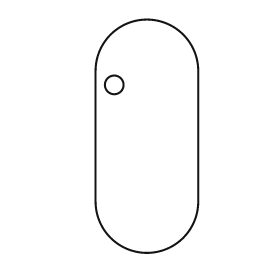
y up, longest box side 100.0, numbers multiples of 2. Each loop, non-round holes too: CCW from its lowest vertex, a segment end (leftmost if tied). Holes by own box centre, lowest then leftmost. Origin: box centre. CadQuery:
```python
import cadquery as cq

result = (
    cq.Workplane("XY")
    .moveTo(-22.0, -28.0)
    .threePointArc((0.0, -50.0), (22.0, -28.0))
    .lineTo(22.0, 28.0)
    .threePointArc((0.0, 50.0), (-22.0, 28.0))
    .close()
    .moveTo(-14.0, 22.0)
    .circle(4.0)
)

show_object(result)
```